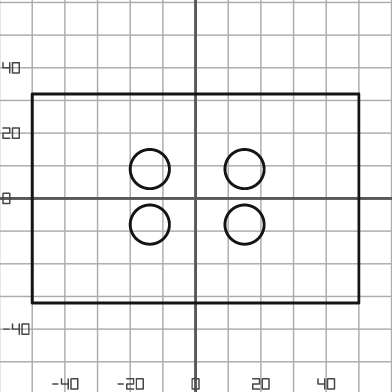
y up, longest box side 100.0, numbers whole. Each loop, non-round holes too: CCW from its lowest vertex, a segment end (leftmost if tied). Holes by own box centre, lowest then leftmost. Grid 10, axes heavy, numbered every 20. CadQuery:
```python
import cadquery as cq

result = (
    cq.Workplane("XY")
    .moveTo(-50.0, -32.0)
    .lineTo(50.0, -32.0)
    .lineTo(50.0, 32.0)
    .lineTo(-50.0, 32.0)
    .close()
    .moveTo(-14.0, -8.0)
    .circle(6.0)
    .moveTo(15.0, -8.0)
    .circle(6.0)
    .moveTo(-14.0, 9.0)
    .circle(6.0)
    .moveTo(15.0, 9.0)
    .circle(6.0)
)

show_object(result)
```